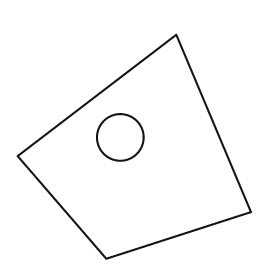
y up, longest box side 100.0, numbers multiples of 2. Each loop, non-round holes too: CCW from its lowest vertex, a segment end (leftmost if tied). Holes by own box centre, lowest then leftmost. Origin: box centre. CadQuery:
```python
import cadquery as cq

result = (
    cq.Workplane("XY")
    .moveTo(-12.0, -48.0)
    .lineTo(50.0, -28.0)
    .lineTo(18.0, 48.0)
    .lineTo(-50.0, -4.0)
    .close()
    .moveTo(-6.0, 4.0)
    .circle(10.0)
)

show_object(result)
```